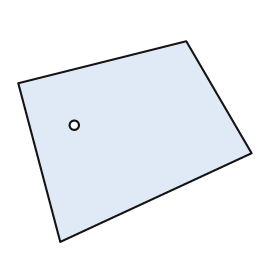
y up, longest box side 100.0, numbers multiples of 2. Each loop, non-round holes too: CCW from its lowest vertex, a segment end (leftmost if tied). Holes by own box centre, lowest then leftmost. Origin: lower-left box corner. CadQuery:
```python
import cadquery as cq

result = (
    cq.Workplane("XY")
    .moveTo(18.0, 0.0)
    .lineTo(100.0, 38.0)
    .lineTo(72.0, 86.0)
    .lineTo(0.0, 68.0)
    .close()
    .moveTo(24.0, 50.0)
    .circle(2.0)
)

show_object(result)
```